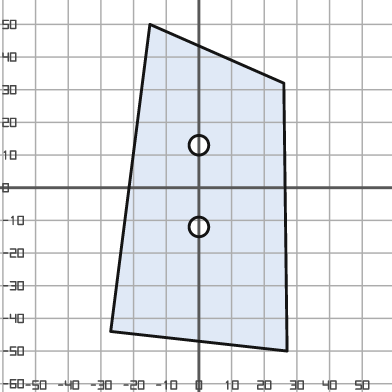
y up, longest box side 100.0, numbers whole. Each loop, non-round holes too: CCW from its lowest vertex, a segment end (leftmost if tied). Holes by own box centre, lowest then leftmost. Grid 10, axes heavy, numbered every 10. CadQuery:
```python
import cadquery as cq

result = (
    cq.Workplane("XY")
    .moveTo(27.0, -50.0)
    .lineTo(26.0, 32.0)
    .lineTo(-15.0, 50.0)
    .lineTo(-27.0, -44.0)
    .close()
    .moveTo(0.0, -12.0)
    .circle(3.0)
    .moveTo(0.0, 13.0)
    .circle(3.0)
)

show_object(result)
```